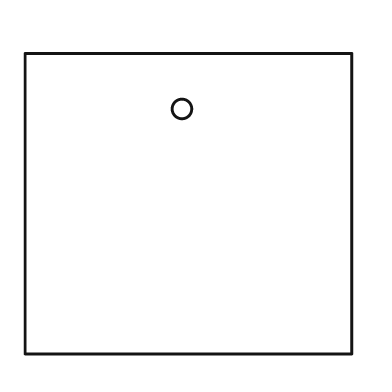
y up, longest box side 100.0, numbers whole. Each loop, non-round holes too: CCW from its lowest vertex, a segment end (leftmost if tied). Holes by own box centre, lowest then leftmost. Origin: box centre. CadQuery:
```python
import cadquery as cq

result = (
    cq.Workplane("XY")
    .moveTo(-50.0, -46.0)
    .lineTo(50.0, -46.0)
    .lineTo(50.0, 46.0)
    .lineTo(-50.0, 46.0)
    .close()
    .moveTo(-2.0, 29.0)
    .circle(3.0)
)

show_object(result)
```